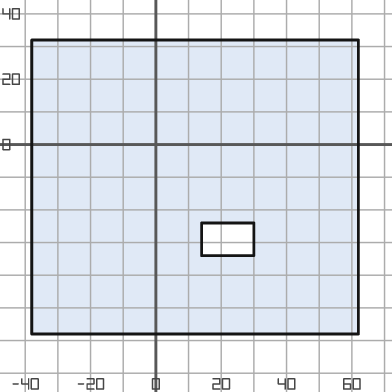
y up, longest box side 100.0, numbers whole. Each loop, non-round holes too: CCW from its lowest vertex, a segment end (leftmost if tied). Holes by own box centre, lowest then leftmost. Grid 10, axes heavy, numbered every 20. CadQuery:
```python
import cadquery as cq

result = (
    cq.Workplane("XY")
    .moveTo(-38.0, -58.0)
    .lineTo(62.0, -58.0)
    .lineTo(62.0, 32.0)
    .lineTo(-38.0, 32.0)
    .close()
    .moveTo(14.0, -34.0)
    .lineTo(30.0, -34.0)
    .lineTo(30.0, -24.0)
    .lineTo(14.0, -24.0)
    .close()
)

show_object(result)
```